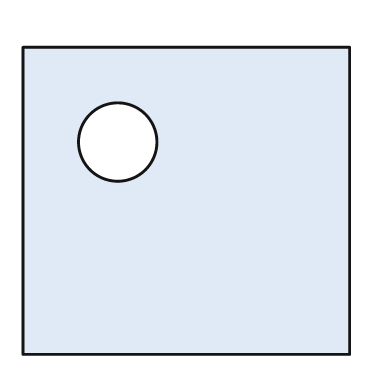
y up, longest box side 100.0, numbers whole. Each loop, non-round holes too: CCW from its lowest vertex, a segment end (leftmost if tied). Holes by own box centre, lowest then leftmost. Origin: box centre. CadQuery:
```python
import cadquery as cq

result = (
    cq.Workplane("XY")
    .moveTo(-50.0, -47.0)
    .lineTo(50.0, -47.0)
    .lineTo(50.0, 47.0)
    .lineTo(-50.0, 47.0)
    .close()
    .moveTo(-21.0, 18.0)
    .circle(12.0)
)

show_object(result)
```